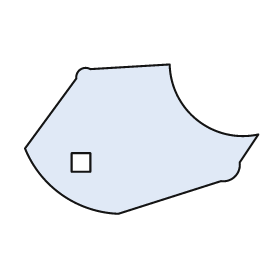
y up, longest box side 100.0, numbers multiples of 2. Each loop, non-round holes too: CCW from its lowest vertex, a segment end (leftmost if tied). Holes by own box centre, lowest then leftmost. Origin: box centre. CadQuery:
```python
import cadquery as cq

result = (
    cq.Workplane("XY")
    .moveTo(-10.0, -32.0)
    .lineTo(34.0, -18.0)
    .threePointArc((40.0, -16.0), (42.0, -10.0))
    .lineTo(50.0, 2.0)
    .threePointArc((24.0, 8.0), (12.0, 32.0))
    .lineTo(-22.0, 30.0)
    .threePointArc((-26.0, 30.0), (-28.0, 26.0))
    .lineTo(-50.0, -4.0)
    .threePointArc((-34.0, -24.0), (-10.0, -32.0))
    .close()
    .moveTo(-30.0, -14.0)
    .lineTo(-22.0, -14.0)
    .lineTo(-22.0, -6.0)
    .lineTo(-30.0, -6.0)
    .close()
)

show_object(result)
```